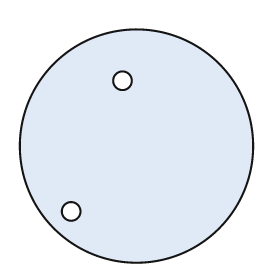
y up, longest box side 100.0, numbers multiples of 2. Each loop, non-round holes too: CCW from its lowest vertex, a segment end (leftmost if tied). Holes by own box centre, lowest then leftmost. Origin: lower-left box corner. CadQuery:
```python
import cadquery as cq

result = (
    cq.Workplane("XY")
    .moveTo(50.0, 50.0)
    .circle(50.0)
    .moveTo(22.0, 22.0)
    .circle(4.0)
    .moveTo(44.0, 78.0)
    .circle(4.0)
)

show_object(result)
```